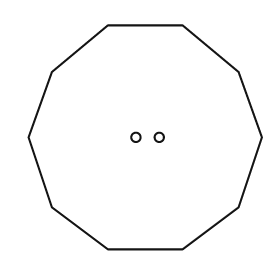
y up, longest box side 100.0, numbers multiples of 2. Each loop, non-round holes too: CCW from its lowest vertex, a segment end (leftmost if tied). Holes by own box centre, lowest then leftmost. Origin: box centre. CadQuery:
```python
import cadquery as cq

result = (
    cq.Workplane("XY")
    .moveTo(-16.0, -48.0)
    .lineTo(16.0, -48.0)
    .lineTo(40.0, -30.0)
    .lineTo(50.0, 0.0)
    .lineTo(40.0, 28.0)
    .lineTo(16.0, 48.0)
    .lineTo(-16.0, 48.0)
    .lineTo(-40.0, 28.0)
    .lineTo(-50.0, 0.0)
    .lineTo(-40.0, -30.0)
    .close()
    .moveTo(-4.0, 0.0)
    .circle(2.0)
    .moveTo(6.0, 0.0)
    .circle(2.0)
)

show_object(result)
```